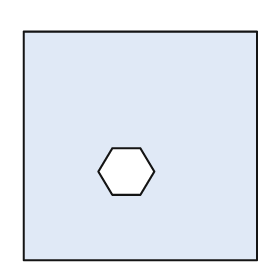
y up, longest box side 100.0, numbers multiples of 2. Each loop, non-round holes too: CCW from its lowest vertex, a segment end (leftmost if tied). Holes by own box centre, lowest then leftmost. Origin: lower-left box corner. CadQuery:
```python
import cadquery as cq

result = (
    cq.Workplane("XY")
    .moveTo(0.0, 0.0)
    .lineTo(100.0, 0.0)
    .lineTo(100.0, 98.0)
    .lineTo(0.0, 98.0)
    .close()
    .moveTo(38.0, 28.0)
    .lineTo(50.0, 28.0)
    .lineTo(56.0, 38.0)
    .lineTo(50.0, 48.0)
    .lineTo(38.0, 48.0)
    .lineTo(32.0, 38.0)
    .close()
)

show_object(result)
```